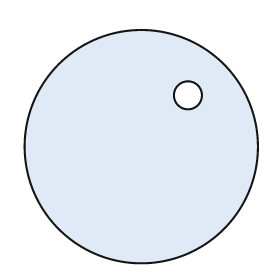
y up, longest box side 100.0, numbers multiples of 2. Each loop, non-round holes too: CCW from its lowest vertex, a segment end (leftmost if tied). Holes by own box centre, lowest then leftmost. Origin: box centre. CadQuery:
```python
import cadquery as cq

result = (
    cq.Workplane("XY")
    .moveTo(0.0, 0.0)
    .circle(50.0)
    .moveTo(20.0, 22.0)
    .circle(6.0)
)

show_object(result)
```